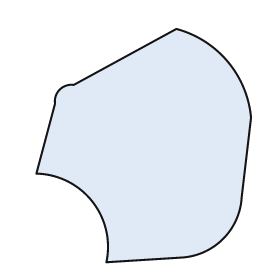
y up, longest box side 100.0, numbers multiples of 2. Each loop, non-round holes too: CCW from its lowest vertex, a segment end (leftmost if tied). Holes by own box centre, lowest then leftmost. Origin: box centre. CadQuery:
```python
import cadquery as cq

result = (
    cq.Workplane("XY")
    .moveTo(-16.0, -50.0)
    .lineTo(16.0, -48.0)
    .threePointArc((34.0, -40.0), (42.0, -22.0))
    .lineTo(46.0, 12.0)
    .threePointArc((36.0, 36.0), (14.0, 50.0))
    .lineTo(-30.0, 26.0)
    .threePointArc((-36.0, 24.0), (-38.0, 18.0))
    .lineTo(-46.0, -12.0)
    .threePointArc((-22.0, -24.0), (-16.0, -50.0))
    .close()
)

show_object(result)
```